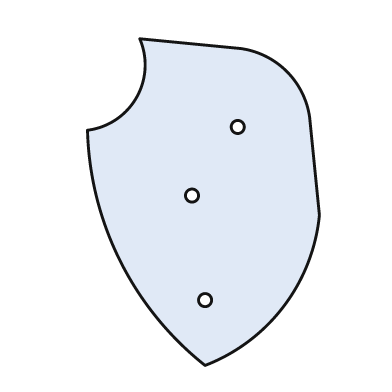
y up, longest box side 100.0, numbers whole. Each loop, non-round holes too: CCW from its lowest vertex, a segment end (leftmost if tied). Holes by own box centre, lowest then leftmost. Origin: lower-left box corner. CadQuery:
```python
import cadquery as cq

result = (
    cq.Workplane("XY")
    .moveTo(36.0, 0.0)
    .threePointArc((60.0, 18.0), (71.0, 46.0))
    .lineTo(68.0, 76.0)
    .threePointArc((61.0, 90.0), (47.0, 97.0))
    .lineTo(16.0, 100.0)
    .threePointArc((15.0, 82.0), (0.0, 72.0))
    .threePointArc((10.0, 32.0), (36.0, 0.0))
    .close()
    .moveTo(36.0, 20.0)
    .circle(2.0)
    .moveTo(32.0, 52.0)
    .circle(2.0)
    .moveTo(46.0, 73.0)
    .circle(2.0)
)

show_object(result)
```